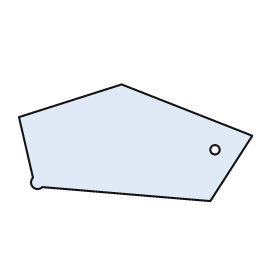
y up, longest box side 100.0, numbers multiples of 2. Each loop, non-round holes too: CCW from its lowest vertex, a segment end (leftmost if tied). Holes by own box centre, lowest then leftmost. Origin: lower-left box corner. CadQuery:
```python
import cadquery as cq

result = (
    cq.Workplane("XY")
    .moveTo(82.0, 0.0)
    .lineTo(100.0, 28.0)
    .lineTo(44.0, 50.0)
    .lineTo(0.0, 36.0)
    .lineTo(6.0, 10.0)
    .threePointArc((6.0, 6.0), (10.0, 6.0))
    .close()
    .moveTo(84.0, 22.0)
    .circle(2.0)
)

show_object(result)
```